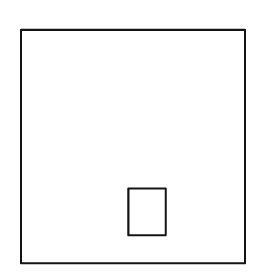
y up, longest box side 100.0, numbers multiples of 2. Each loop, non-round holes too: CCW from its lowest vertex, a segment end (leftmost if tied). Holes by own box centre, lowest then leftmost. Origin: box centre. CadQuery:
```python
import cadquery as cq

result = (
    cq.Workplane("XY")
    .moveTo(-48.0, -50.0)
    .lineTo(48.0, -50.0)
    .lineTo(48.0, 50.0)
    .lineTo(-48.0, 50.0)
    .close()
    .moveTo(-2.0, -38.0)
    .lineTo(14.0, -38.0)
    .lineTo(14.0, -18.0)
    .lineTo(-2.0, -18.0)
    .close()
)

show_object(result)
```